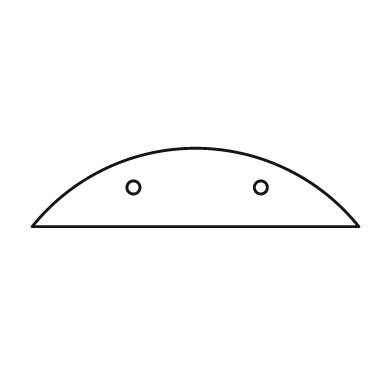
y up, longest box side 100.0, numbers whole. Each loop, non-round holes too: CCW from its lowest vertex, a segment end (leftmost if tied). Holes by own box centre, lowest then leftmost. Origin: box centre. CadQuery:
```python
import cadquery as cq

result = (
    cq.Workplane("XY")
    .moveTo(-50.0, -12.0)
    .lineTo(50.0, -12.0)
    .threePointArc((0.0, 12.0), (-50.0, -12.0))
    .close()
    .moveTo(-19.0, 0.0)
    .circle(2.0)
    .moveTo(20.0, 0.0)
    .circle(2.0)
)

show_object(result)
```